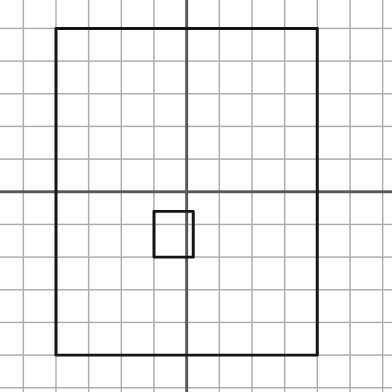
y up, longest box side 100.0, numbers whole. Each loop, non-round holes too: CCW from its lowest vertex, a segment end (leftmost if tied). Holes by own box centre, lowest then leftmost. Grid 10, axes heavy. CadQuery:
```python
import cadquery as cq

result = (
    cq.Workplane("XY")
    .moveTo(-40.0, -50.0)
    .lineTo(40.0, -50.0)
    .lineTo(40.0, 50.0)
    .lineTo(-40.0, 50.0)
    .close()
    .moveTo(-10.0, -20.0)
    .lineTo(2.0, -20.0)
    .lineTo(2.0, -6.0)
    .lineTo(-10.0, -6.0)
    .close()
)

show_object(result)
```